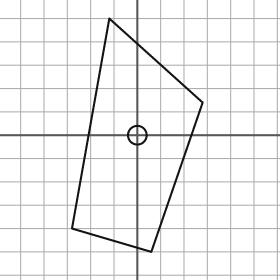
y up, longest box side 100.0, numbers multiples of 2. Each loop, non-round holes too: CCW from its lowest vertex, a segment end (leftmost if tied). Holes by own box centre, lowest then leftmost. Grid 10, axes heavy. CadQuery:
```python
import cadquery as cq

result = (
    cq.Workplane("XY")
    .moveTo(6.0, -50.0)
    .lineTo(28.0, 14.0)
    .lineTo(-12.0, 50.0)
    .lineTo(-28.0, -40.0)
    .close()
    .moveTo(0.0, 0.0)
    .circle(4.0)
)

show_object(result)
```